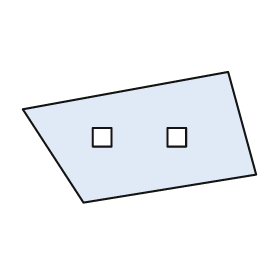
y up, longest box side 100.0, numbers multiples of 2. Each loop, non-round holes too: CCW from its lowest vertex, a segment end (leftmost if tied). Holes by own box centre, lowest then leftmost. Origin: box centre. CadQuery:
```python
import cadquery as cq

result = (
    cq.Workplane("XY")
    .moveTo(-24.0, -28.0)
    .lineTo(50.0, -16.0)
    .lineTo(38.0, 28.0)
    .lineTo(-50.0, 12.0)
    .close()
    .moveTo(-20.0, -4.0)
    .lineTo(-12.0, -4.0)
    .lineTo(-12.0, 4.0)
    .lineTo(-20.0, 4.0)
    .close()
    .moveTo(12.0, -4.0)
    .lineTo(20.0, -4.0)
    .lineTo(20.0, 4.0)
    .lineTo(12.0, 4.0)
    .close()
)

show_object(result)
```